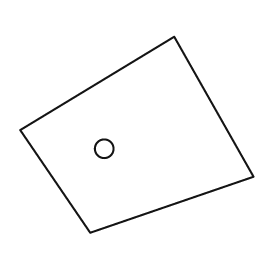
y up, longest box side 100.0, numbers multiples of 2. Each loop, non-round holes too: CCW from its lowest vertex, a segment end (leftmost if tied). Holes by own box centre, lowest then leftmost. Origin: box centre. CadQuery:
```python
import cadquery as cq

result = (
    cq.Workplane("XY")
    .moveTo(-20.0, -42.0)
    .lineTo(50.0, -18.0)
    .lineTo(16.0, 42.0)
    .lineTo(-50.0, 2.0)
    .close()
    .moveTo(-14.0, -6.0)
    .circle(4.0)
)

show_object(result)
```